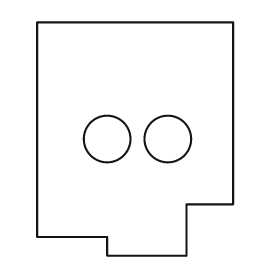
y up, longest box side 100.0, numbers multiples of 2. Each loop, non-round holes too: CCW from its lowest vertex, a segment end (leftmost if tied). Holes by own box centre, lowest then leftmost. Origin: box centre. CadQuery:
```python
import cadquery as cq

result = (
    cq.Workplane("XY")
    .moveTo(-12.0, -50.0)
    .lineTo(22.0, -50.0)
    .lineTo(22.0, -28.0)
    .lineTo(42.0, -28.0)
    .lineTo(42.0, 50.0)
    .lineTo(-42.0, 50.0)
    .lineTo(-42.0, -42.0)
    .lineTo(-12.0, -42.0)
    .close()
    .moveTo(-12.0, 0.0)
    .circle(10.0)
    .moveTo(14.0, 0.0)
    .circle(10.0)
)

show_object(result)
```